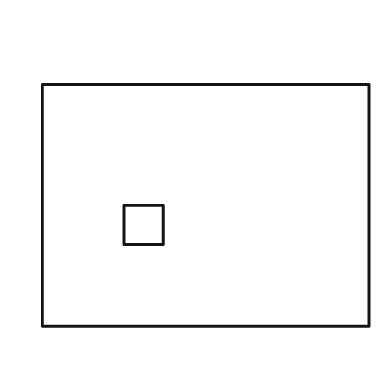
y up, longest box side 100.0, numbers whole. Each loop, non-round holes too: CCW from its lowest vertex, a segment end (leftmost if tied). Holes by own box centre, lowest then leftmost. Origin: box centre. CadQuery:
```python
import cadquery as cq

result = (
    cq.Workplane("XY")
    .moveTo(-50.0, -37.0)
    .lineTo(50.0, -37.0)
    .lineTo(50.0, 37.0)
    .lineTo(-50.0, 37.0)
    .close()
    .moveTo(-25.0, -12.0)
    .lineTo(-13.0, -12.0)
    .lineTo(-13.0, 0.0)
    .lineTo(-25.0, 0.0)
    .close()
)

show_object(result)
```